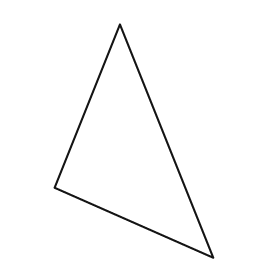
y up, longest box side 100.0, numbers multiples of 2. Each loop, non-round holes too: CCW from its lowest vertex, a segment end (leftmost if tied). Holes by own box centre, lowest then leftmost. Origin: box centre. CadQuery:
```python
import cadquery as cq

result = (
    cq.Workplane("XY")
    .moveTo(34.0, -50.0)
    .lineTo(-6.0, 50.0)
    .lineTo(-34.0, -20.0)
    .close()
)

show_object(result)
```